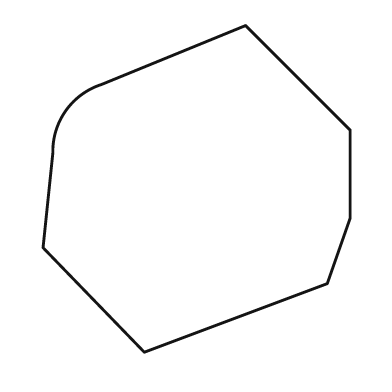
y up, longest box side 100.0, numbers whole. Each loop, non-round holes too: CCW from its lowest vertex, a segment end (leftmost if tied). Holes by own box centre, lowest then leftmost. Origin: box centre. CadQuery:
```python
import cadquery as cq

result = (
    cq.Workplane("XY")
    .moveTo(-16.0, -50.0)
    .lineTo(40.0, -29.0)
    .lineTo(47.0, -9.0)
    .lineTo(47.0, 18.0)
    .lineTo(15.0, 50.0)
    .lineTo(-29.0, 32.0)
    .threePointArc((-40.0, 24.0), (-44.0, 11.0))
    .lineTo(-47.0, -18.0)
    .close()
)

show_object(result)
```